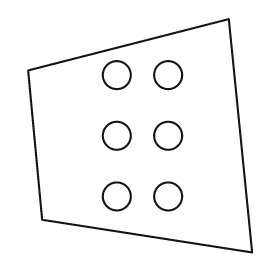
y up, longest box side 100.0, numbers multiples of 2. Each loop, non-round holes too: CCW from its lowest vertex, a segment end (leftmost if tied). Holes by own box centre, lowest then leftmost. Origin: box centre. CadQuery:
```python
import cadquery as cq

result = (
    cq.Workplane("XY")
    .moveTo(48.0, -50.0)
    .lineTo(38.0, 50.0)
    .lineTo(-48.0, 28.0)
    .lineTo(-42.0, -36.0)
    .close()
    .moveTo(-10.0, -26.0)
    .circle(6.0)
    .moveTo(12.0, -26.0)
    .circle(6.0)
    .moveTo(-10.0, 0.0)
    .circle(6.0)
    .moveTo(12.0, 0.0)
    .circle(6.0)
    .moveTo(-10.0, 26.0)
    .circle(6.0)
    .moveTo(12.0, 26.0)
    .circle(6.0)
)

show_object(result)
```